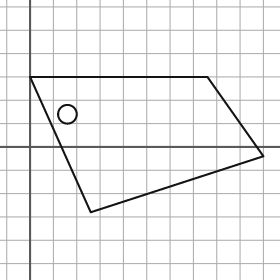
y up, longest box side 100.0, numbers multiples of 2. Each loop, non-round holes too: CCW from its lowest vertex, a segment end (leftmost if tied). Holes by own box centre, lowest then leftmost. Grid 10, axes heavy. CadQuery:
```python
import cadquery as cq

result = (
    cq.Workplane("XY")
    .moveTo(26.0, -28.0)
    .lineTo(100.0, -4.0)
    .lineTo(76.0, 30.0)
    .lineTo(0.0, 30.0)
    .close()
    .moveTo(16.0, 14.0)
    .circle(4.0)
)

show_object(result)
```